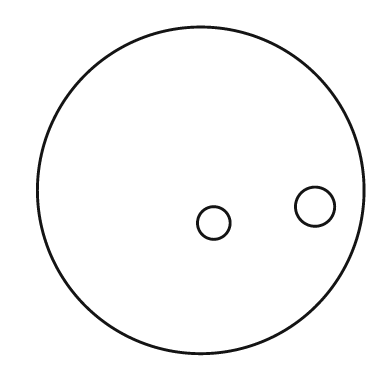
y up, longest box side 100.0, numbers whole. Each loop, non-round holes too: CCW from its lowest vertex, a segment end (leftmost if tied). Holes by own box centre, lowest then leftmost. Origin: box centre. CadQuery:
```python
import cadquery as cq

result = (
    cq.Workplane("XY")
    .moveTo(0.0, 0.0)
    .circle(50.0)
    .moveTo(4.0, -10.0)
    .circle(5.0)
    .moveTo(35.0, -5.0)
    .circle(6.0)
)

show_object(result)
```